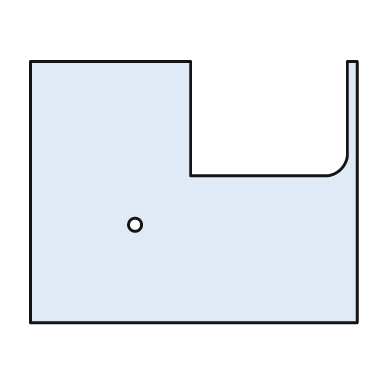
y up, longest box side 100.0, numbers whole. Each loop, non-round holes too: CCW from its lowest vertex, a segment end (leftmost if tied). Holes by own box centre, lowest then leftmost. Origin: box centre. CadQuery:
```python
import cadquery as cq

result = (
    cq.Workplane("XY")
    .moveTo(-50.0, -40.0)
    .lineTo(50.0, -40.0)
    .lineTo(50.0, 40.0)
    .lineTo(47.0, 40.0)
    .lineTo(47.0, 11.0)
    .threePointArc((45.0, 7.0), (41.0, 5.0))
    .lineTo(-1.0, 5.0)
    .lineTo(-1.0, 40.0)
    .lineTo(-50.0, 40.0)
    .close()
    .moveTo(-18.0, -10.0)
    .circle(2.0)
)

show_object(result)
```